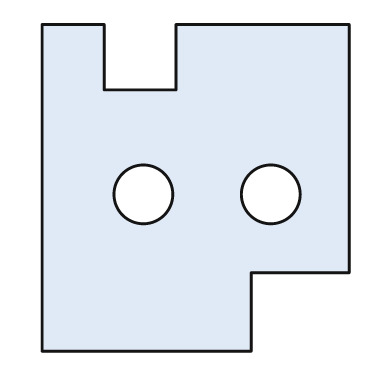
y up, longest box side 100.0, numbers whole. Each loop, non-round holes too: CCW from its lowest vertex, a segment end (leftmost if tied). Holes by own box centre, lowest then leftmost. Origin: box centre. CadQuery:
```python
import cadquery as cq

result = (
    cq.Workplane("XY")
    .moveTo(-47.0, -50.0)
    .lineTo(17.0, -50.0)
    .lineTo(17.0, -26.0)
    .lineTo(47.0, -26.0)
    .lineTo(47.0, 50.0)
    .lineTo(-6.0, 50.0)
    .lineTo(-6.0, 30.0)
    .lineTo(-28.0, 30.0)
    .lineTo(-28.0, 50.0)
    .lineTo(-47.0, 50.0)
    .close()
    .moveTo(-16.0, -2.0)
    .circle(9.0)
    .moveTo(23.0, -2.0)
    .circle(9.0)
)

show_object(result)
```